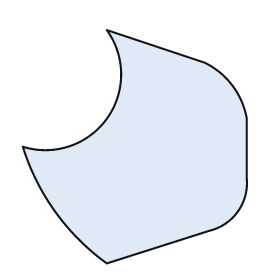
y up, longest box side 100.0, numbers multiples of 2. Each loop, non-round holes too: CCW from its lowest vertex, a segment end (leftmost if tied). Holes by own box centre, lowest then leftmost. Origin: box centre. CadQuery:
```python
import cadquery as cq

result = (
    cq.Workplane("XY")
    .moveTo(-12.0, -50.0)
    .lineTo(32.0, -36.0)
    .threePointArc((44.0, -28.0), (48.0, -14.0))
    .lineTo(48.0, 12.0)
    .threePointArc((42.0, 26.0), (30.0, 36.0))
    .lineTo(-12.0, 50.0)
    .threePointArc((-12.0, 12.0), (-48.0, 0.0))
    .threePointArc((-34.0, -28.0), (-12.0, -50.0))
    .close()
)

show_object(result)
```